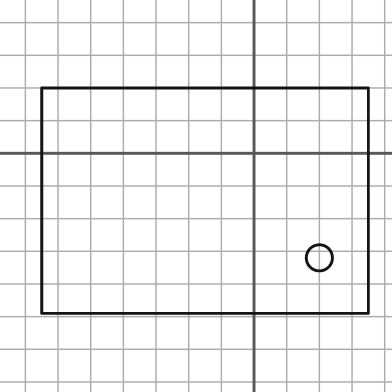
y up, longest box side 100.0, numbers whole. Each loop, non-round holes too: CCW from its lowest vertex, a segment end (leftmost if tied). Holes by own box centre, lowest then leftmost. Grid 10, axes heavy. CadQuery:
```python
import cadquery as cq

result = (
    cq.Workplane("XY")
    .moveTo(-65.0, -49.0)
    .lineTo(35.0, -49.0)
    .lineTo(35.0, 20.0)
    .lineTo(-65.0, 20.0)
    .close()
    .moveTo(20.0, -32.0)
    .circle(4.0)
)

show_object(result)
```